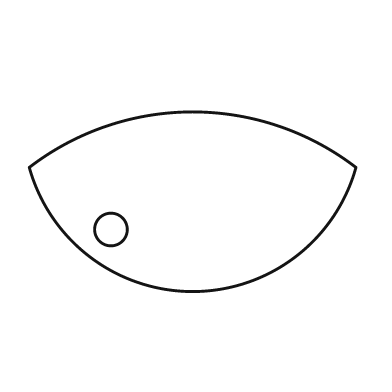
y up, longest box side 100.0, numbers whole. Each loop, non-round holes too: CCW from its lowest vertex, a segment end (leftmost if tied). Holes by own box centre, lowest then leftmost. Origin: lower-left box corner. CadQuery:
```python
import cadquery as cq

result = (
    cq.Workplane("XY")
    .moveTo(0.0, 38.0)
    .threePointArc((50.0, 0.0), (100.0, 38.0))
    .threePointArc((50.0, 55.0), (0.0, 38.0))
    .close()
    .moveTo(25.0, 19.0)
    .circle(5.0)
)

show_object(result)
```